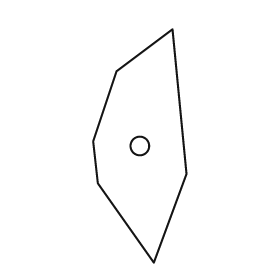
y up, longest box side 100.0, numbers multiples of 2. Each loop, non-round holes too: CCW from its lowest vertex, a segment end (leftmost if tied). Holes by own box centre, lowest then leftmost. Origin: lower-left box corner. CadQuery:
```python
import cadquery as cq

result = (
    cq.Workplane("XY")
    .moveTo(26.0, 0.0)
    .lineTo(40.0, 38.0)
    .lineTo(34.0, 100.0)
    .lineTo(10.0, 82.0)
    .lineTo(0.0, 52.0)
    .lineTo(2.0, 34.0)
    .close()
    .moveTo(20.0, 50.0)
    .circle(4.0)
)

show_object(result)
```